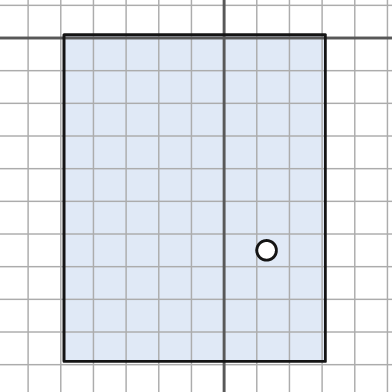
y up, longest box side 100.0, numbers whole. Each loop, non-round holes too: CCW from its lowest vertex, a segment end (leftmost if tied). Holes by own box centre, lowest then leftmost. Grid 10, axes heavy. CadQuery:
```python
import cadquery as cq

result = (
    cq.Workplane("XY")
    .moveTo(-49.0, -99.0)
    .lineTo(31.0, -99.0)
    .lineTo(31.0, 1.0)
    .lineTo(-49.0, 1.0)
    .close()
    .moveTo(13.0, -65.0)
    .circle(3.0)
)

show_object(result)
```